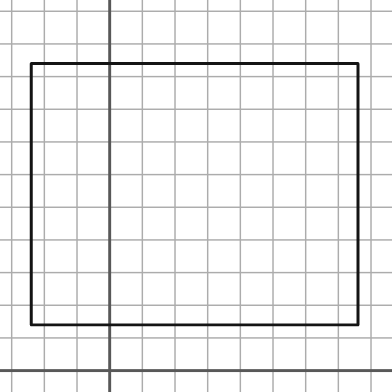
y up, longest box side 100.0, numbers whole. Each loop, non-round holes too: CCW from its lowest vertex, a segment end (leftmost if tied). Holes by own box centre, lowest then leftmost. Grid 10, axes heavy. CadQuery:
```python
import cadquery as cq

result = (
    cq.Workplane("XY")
    .moveTo(-24.0, 14.0)
    .lineTo(76.0, 14.0)
    .lineTo(76.0, 94.0)
    .lineTo(-24.0, 94.0)
    .close()
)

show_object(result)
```